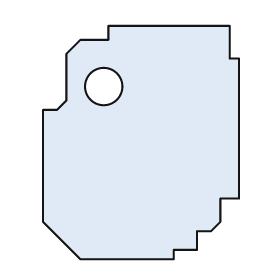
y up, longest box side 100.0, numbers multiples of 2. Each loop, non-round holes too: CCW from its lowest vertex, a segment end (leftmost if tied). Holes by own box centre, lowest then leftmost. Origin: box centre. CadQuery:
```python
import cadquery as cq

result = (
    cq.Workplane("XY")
    .moveTo(-26.0, -50.0)
    .lineTo(14.0, -50.0)
    .lineTo(14.0, -46.0)
    .lineTo(24.0, -46.0)
    .lineTo(24.0, -38.0)
    .lineTo(30.0, -38.0)
    .lineTo(34.0, -34.0)
    .lineTo(34.0, -24.0)
    .lineTo(42.0, -24.0)
    .lineTo(42.0, 36.0)
    .lineTo(38.0, 36.0)
    .lineTo(38.0, 50.0)
    .lineTo(-14.0, 50.0)
    .lineTo(-14.0, 44.0)
    .lineTo(-26.0, 44.0)
    .lineTo(-32.0, 38.0)
    .lineTo(-32.0, 18.0)
    .lineTo(-36.0, 14.0)
    .lineTo(-42.0, 14.0)
    .lineTo(-42.0, -34.0)
    .close()
    .moveTo(-16.0, 24.0)
    .circle(8.0)
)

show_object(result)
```